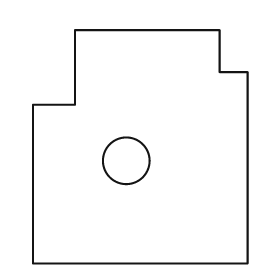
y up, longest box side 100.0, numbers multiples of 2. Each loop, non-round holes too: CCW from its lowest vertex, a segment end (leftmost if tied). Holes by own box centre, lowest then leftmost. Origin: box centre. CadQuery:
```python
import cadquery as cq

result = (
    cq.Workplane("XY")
    .moveTo(-46.0, -50.0)
    .lineTo(46.0, -50.0)
    .lineTo(46.0, 32.0)
    .lineTo(34.0, 32.0)
    .lineTo(34.0, 50.0)
    .lineTo(-28.0, 50.0)
    .lineTo(-28.0, 18.0)
    .lineTo(-46.0, 18.0)
    .close()
    .moveTo(-6.0, -6.0)
    .circle(10.0)
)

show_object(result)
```